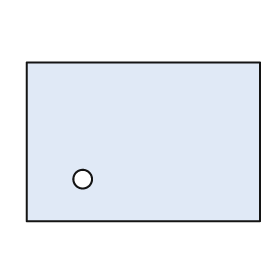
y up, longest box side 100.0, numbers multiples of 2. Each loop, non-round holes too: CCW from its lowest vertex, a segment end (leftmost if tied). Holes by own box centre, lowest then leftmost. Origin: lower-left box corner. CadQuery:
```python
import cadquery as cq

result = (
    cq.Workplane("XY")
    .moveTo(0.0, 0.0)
    .lineTo(100.0, 0.0)
    .lineTo(100.0, 68.0)
    .lineTo(0.0, 68.0)
    .close()
    .moveTo(24.0, 18.0)
    .circle(4.0)
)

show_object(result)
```